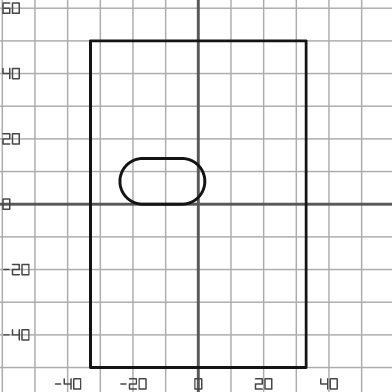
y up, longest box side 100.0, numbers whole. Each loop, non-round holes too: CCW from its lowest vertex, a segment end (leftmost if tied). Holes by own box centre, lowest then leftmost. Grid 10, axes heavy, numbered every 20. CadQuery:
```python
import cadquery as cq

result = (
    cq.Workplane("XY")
    .moveTo(-33.0, -50.0)
    .lineTo(33.0, -50.0)
    .lineTo(33.0, 50.0)
    .lineTo(-33.0, 50.0)
    .close()
    .moveTo(-17.0, 0.0)
    .lineTo(-5.0, 0.0)
    .threePointArc((2.0, 7.0), (-5.0, 14.0))
    .lineTo(-17.0, 14.0)
    .threePointArc((-24.0, 7.0), (-17.0, 0.0))
    .close()
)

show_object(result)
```